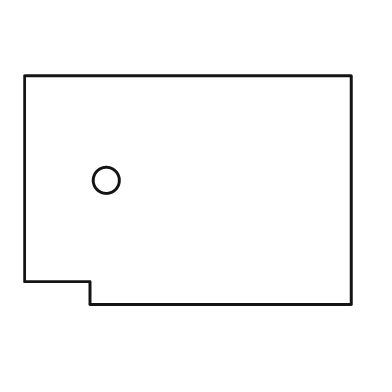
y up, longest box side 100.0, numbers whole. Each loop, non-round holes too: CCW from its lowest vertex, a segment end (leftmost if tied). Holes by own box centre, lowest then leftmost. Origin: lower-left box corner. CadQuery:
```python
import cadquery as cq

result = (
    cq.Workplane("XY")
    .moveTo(20.0, 0.0)
    .lineTo(100.0, 0.0)
    .lineTo(100.0, 70.0)
    .lineTo(0.0, 70.0)
    .lineTo(0.0, 7.0)
    .lineTo(20.0, 7.0)
    .close()
    .moveTo(25.0, 38.0)
    .circle(4.0)
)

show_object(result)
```